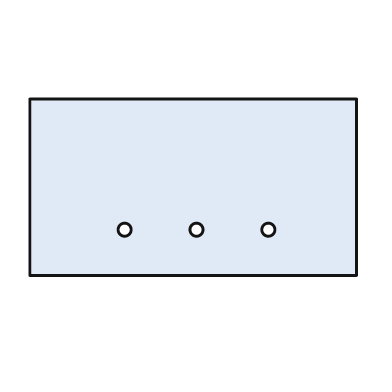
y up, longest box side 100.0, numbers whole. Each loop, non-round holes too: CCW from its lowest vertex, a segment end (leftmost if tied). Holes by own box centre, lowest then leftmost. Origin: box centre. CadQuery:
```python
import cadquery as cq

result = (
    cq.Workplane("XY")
    .moveTo(-50.0, -27.0)
    .lineTo(50.0, -27.0)
    .lineTo(50.0, 27.0)
    .lineTo(-50.0, 27.0)
    .close()
    .moveTo(-21.0, -13.0)
    .circle(2.0)
    .moveTo(1.0, -13.0)
    .circle(2.0)
    .moveTo(23.0, -13.0)
    .circle(2.0)
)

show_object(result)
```